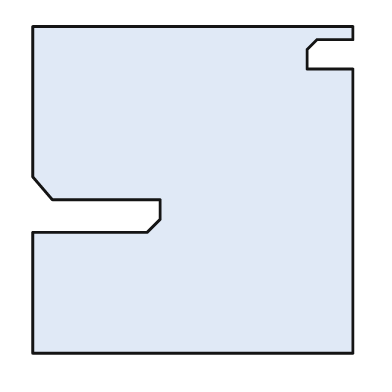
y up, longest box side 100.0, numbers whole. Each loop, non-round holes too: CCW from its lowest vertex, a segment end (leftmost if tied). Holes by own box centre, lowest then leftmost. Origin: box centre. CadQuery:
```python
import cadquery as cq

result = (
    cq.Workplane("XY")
    .moveTo(-49.0, -50.0)
    .lineTo(49.0, -50.0)
    .lineTo(49.0, 37.0)
    .lineTo(35.0, 37.0)
    .lineTo(35.0, 43.0)
    .lineTo(38.0, 46.0)
    .lineTo(49.0, 46.0)
    .lineTo(49.0, 50.0)
    .lineTo(-49.0, 50.0)
    .lineTo(-49.0, 4.0)
    .lineTo(-43.0, -3.0)
    .lineTo(-10.0, -3.0)
    .lineTo(-10.0, -9.0)
    .lineTo(-14.0, -13.0)
    .lineTo(-49.0, -13.0)
    .close()
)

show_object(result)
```